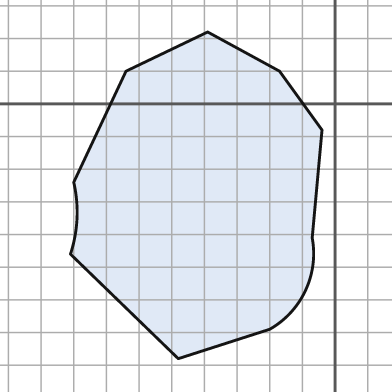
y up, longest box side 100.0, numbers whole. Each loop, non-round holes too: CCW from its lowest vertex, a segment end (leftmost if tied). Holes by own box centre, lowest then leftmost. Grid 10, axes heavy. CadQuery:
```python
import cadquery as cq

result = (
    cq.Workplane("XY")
    .moveTo(-48.0, -78.0)
    .lineTo(-20.0, -69.0)
    .threePointArc((-9.0, -57.0), (-7.0, -41.0))
    .lineTo(-4.0, -8.0)
    .lineTo(-17.0, 10.0)
    .lineTo(-39.0, 22.0)
    .lineTo(-64.0, 10.0)
    .lineTo(-80.0, -24.0)
    .threePointArc((-79.0, -35.0), (-81.0, -46.0))
    .close()
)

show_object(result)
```